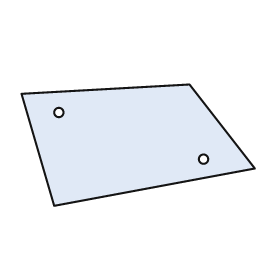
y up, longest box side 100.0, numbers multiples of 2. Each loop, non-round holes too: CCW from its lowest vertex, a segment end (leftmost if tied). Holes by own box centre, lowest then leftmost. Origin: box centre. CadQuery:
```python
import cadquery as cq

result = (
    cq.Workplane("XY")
    .moveTo(-36.0, -26.0)
    .lineTo(50.0, -10.0)
    .lineTo(22.0, 26.0)
    .lineTo(-50.0, 22.0)
    .close()
    .moveTo(28.0, -6.0)
    .circle(2.0)
    .moveTo(-34.0, 14.0)
    .circle(2.0)
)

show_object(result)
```